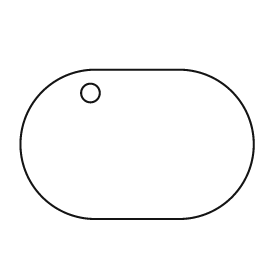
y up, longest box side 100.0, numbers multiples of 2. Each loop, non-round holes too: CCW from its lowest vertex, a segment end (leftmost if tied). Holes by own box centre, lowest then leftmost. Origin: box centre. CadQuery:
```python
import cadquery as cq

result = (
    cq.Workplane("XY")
    .moveTo(-18.0, -32.0)
    .lineTo(18.0, -32.0)
    .threePointArc((50.0, 0.0), (18.0, 32.0))
    .lineTo(-18.0, 32.0)
    .threePointArc((-50.0, 0.0), (-18.0, -32.0))
    .close()
    .moveTo(-20.0, 22.0)
    .circle(4.0)
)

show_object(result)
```